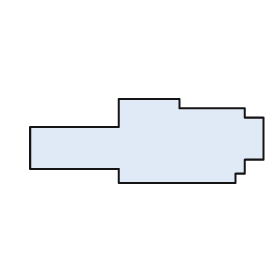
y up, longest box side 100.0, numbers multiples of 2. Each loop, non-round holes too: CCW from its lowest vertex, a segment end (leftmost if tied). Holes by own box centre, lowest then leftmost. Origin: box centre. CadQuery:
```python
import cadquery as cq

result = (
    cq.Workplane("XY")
    .moveTo(-12.0, -18.0)
    .lineTo(38.0, -18.0)
    .lineTo(38.0, -14.0)
    .lineTo(42.0, -14.0)
    .lineTo(42.0, -8.0)
    .lineTo(50.0, -8.0)
    .lineTo(50.0, 10.0)
    .lineTo(42.0, 10.0)
    .lineTo(42.0, 14.0)
    .lineTo(14.0, 14.0)
    .lineTo(14.0, 18.0)
    .lineTo(-12.0, 18.0)
    .lineTo(-12.0, 6.0)
    .lineTo(-50.0, 6.0)
    .lineTo(-50.0, -12.0)
    .lineTo(-12.0, -12.0)
    .close()
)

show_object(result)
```